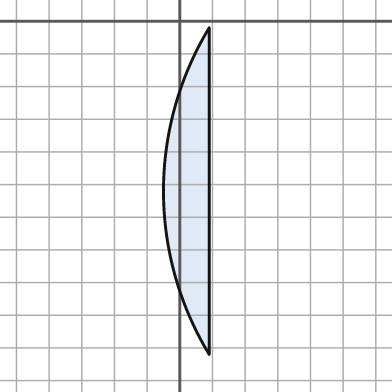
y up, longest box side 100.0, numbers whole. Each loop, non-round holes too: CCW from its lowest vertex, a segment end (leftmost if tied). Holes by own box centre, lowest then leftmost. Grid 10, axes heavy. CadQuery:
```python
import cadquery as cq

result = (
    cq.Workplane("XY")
    .moveTo(9.0, -102.0)
    .lineTo(9.0, -2.0)
    .threePointArc((-5.0, -52.0), (9.0, -102.0))
    .close()
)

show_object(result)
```